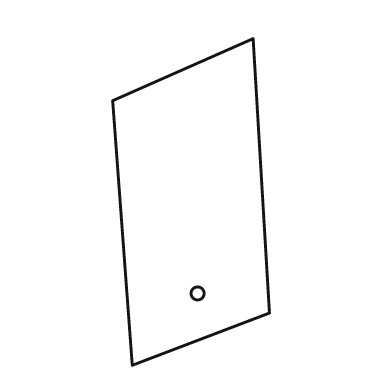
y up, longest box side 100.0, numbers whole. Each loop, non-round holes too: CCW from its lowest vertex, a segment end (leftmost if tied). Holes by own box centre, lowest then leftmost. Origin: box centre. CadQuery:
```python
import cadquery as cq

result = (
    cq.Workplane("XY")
    .moveTo(-18.0, -50.0)
    .lineTo(24.0, -34.0)
    .lineTo(19.0, 50.0)
    .lineTo(-24.0, 31.0)
    .close()
    .moveTo(2.0, -28.0)
    .circle(2.0)
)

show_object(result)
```